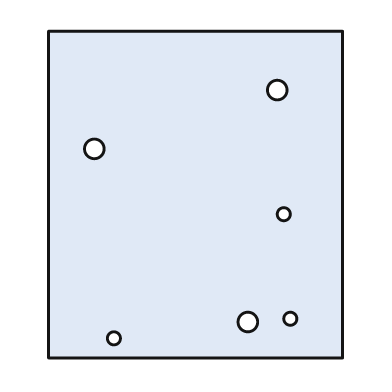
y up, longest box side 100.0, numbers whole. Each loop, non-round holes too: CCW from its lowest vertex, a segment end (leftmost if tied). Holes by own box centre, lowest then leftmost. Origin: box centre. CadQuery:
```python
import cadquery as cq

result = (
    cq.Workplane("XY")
    .moveTo(-45.0, -50.0)
    .lineTo(45.0, -50.0)
    .lineTo(45.0, 50.0)
    .lineTo(-45.0, 50.0)
    .close()
    .moveTo(-25.0, -44.0)
    .circle(2.0)
    .moveTo(16.0, -39.0)
    .circle(3.0)
    .moveTo(29.0, -38.0)
    .circle(2.0)
    .moveTo(27.0, -6.0)
    .circle(2.0)
    .moveTo(-31.0, 14.0)
    .circle(3.0)
    .moveTo(25.0, 32.0)
    .circle(3.0)
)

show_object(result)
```